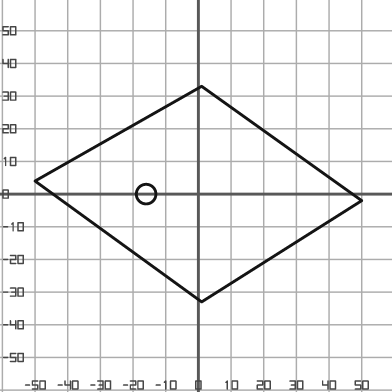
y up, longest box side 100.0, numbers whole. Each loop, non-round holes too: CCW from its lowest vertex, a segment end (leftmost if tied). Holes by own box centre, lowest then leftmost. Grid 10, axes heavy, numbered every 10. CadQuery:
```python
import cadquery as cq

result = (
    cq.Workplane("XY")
    .moveTo(1.0, -33.0)
    .lineTo(50.0, -2.0)
    .lineTo(1.0, 33.0)
    .lineTo(-50.0, 4.0)
    .close()
    .moveTo(-16.0, 0.0)
    .circle(3.0)
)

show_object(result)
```